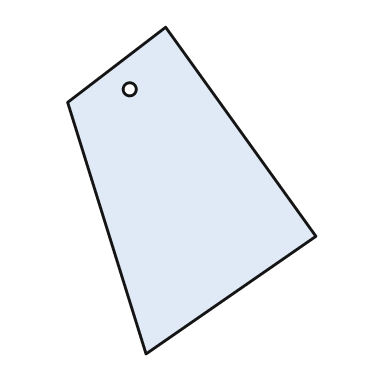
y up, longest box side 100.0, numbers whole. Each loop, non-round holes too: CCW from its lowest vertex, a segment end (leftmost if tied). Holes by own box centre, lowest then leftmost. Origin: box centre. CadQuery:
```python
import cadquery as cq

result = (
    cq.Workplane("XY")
    .moveTo(-14.0, -50.0)
    .lineTo(38.0, -14.0)
    .lineTo(-8.0, 50.0)
    .lineTo(-38.0, 27.0)
    .close()
    .moveTo(-19.0, 31.0)
    .circle(2.0)
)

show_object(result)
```